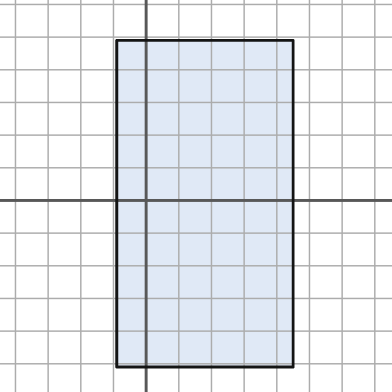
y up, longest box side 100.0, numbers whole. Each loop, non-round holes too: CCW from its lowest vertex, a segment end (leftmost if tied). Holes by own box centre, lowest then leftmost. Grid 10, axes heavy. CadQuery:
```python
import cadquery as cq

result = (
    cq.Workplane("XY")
    .moveTo(-9.0, -51.0)
    .lineTo(45.0, -51.0)
    .lineTo(45.0, 49.0)
    .lineTo(-9.0, 49.0)
    .close()
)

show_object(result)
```